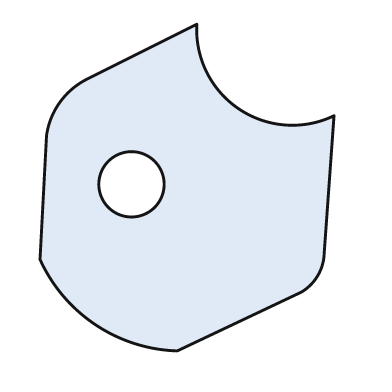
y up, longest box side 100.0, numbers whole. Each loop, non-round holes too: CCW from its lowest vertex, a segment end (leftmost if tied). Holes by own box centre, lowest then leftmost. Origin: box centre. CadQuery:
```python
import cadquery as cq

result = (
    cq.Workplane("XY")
    .moveTo(-3.0, -50.0)
    .lineTo(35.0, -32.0)
    .threePointArc((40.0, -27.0), (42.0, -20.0))
    .lineTo(45.0, 22.0)
    .threePointArc((16.0, 24.0), (3.0, 50.0))
    .lineTo(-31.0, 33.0)
    .threePointArc((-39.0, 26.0), (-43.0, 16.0))
    .lineTo(-45.0, -22.0)
    .threePointArc((-28.0, -42.0), (-3.0, -50.0))
    .close()
    .moveTo(-17.0, 1.0)
    .circle(10.0)
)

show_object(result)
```